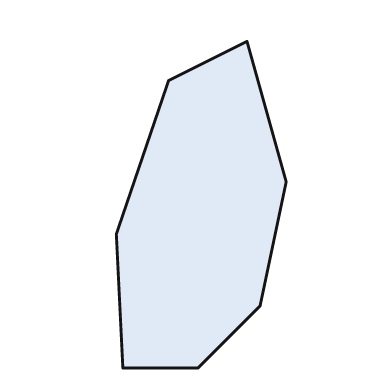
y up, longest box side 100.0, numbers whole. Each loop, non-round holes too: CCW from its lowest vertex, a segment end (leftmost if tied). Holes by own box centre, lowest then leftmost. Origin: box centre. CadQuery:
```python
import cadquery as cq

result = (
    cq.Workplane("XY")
    .moveTo(-24.0, -50.0)
    .lineTo(-1.0, -50.0)
    .lineTo(18.0, -31.0)
    .lineTo(26.0, 7.0)
    .lineTo(14.0, 50.0)
    .lineTo(-10.0, 38.0)
    .lineTo(-26.0, -9.0)
    .close()
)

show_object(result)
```